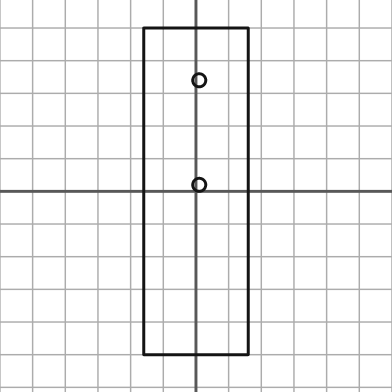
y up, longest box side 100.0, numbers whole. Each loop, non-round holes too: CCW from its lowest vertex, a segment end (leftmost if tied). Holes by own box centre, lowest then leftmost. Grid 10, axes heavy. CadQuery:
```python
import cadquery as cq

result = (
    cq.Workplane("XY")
    .moveTo(-16.0, -50.0)
    .lineTo(16.0, -50.0)
    .lineTo(16.0, 50.0)
    .lineTo(-16.0, 50.0)
    .close()
    .moveTo(1.0, 2.0)
    .circle(2.0)
    .moveTo(1.0, 34.0)
    .circle(2.0)
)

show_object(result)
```